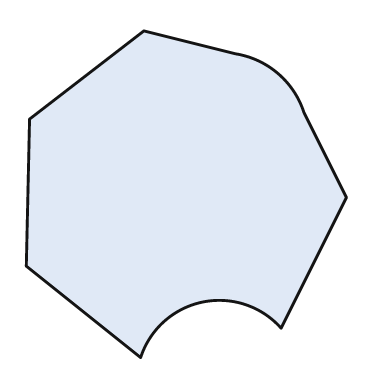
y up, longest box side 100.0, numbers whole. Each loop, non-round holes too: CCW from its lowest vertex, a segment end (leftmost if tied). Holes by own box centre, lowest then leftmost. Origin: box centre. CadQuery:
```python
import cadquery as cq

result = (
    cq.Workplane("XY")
    .moveTo(-14.0, -50.0)
    .threePointArc((5.0, -33.0), (29.0, -41.0))
    .lineTo(49.0, -1.0)
    .lineTo(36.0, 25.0)
    .threePointArc((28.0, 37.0), (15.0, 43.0))
    .lineTo(-13.0, 50.0)
    .lineTo(-48.0, 23.0)
    .lineTo(-49.0, -22.0)
    .close()
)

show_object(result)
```